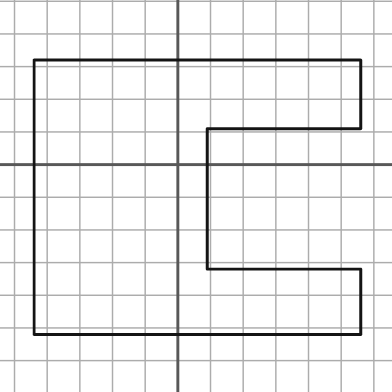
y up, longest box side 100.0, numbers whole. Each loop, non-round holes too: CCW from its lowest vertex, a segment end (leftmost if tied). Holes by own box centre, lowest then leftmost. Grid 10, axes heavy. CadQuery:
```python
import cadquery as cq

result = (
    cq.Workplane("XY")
    .moveTo(-44.0, -52.0)
    .lineTo(56.0, -52.0)
    .lineTo(56.0, -32.0)
    .lineTo(9.0, -32.0)
    .lineTo(9.0, 11.0)
    .lineTo(56.0, 11.0)
    .lineTo(56.0, 32.0)
    .lineTo(-44.0, 32.0)
    .close()
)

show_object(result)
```